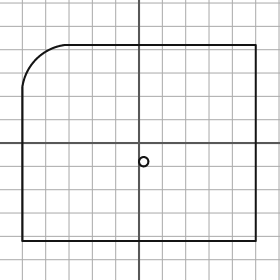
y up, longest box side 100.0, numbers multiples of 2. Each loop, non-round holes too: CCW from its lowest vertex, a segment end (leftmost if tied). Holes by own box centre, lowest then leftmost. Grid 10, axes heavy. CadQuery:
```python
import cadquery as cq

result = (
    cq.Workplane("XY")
    .moveTo(-50.0, -42.0)
    .lineTo(50.0, -42.0)
    .lineTo(50.0, 42.0)
    .lineTo(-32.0, 42.0)
    .threePointArc((-44.0, 36.0), (-50.0, 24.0))
    .close()
    .moveTo(2.0, -8.0)
    .circle(2.0)
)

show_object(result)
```